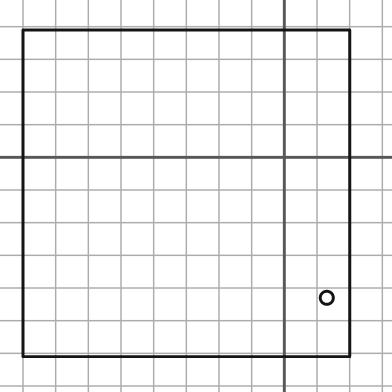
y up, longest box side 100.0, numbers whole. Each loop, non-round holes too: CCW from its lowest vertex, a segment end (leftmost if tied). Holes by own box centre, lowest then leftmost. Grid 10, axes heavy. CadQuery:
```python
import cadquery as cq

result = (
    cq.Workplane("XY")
    .moveTo(-80.0, -61.0)
    .lineTo(20.0, -61.0)
    .lineTo(20.0, 39.0)
    .lineTo(-80.0, 39.0)
    .close()
    .moveTo(13.0, -43.0)
    .circle(2.0)
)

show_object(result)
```